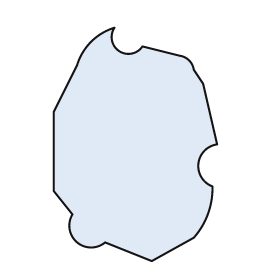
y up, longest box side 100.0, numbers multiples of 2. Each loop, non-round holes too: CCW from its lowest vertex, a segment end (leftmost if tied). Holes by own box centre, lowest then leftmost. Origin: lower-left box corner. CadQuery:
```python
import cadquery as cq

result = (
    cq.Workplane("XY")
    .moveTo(42.0, 0.0)
    .lineTo(60.0, 10.0)
    .threePointArc((66.0, 20.0), (68.0, 32.0))
    .threePointArc((62.0, 42.0), (70.0, 50.0))
    .lineTo(64.0, 76.0)
    .lineTo(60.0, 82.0)
    .threePointArc((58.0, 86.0), (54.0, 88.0))
    .lineTo(38.0, 92.0)
    .threePointArc((28.0, 90.0), (26.0, 100.0))
    .threePointArc((16.0, 94.0), (10.0, 84.0))
    .lineTo(0.0, 64.0)
    .lineTo(0.0, 30.0)
    .lineTo(8.0, 20.0)
    .threePointArc((10.0, 8.0), (22.0, 8.0))
    .close()
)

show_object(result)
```